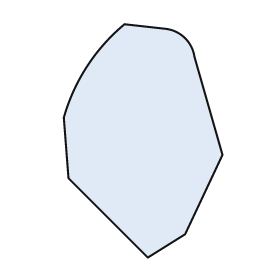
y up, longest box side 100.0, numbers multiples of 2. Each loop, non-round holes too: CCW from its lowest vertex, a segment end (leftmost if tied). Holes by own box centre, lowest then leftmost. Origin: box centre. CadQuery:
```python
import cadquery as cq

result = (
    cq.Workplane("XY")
    .moveTo(2.0, -50.0)
    .lineTo(18.0, -40.0)
    .lineTo(34.0, -6.0)
    .lineTo(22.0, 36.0)
    .threePointArc((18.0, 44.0), (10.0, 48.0))
    .lineTo(-8.0, 50.0)
    .threePointArc((-24.0, 32.0), (-34.0, 10.0))
    .lineTo(-32.0, -16.0)
    .close()
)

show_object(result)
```